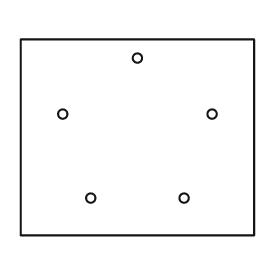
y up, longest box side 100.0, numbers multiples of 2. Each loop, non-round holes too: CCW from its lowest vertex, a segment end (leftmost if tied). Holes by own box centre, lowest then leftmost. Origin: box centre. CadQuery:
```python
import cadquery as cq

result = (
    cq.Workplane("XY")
    .moveTo(-50.0, -42.0)
    .lineTo(50.0, -42.0)
    .lineTo(50.0, 42.0)
    .lineTo(-50.0, 42.0)
    .close()
    .moveTo(-20.0, -26.0)
    .circle(2.0)
    .moveTo(20.0, -26.0)
    .circle(2.0)
    .moveTo(-32.0, 10.0)
    .circle(2.0)
    .moveTo(32.0, 10.0)
    .circle(2.0)
    .moveTo(0.0, 34.0)
    .circle(2.0)
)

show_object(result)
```